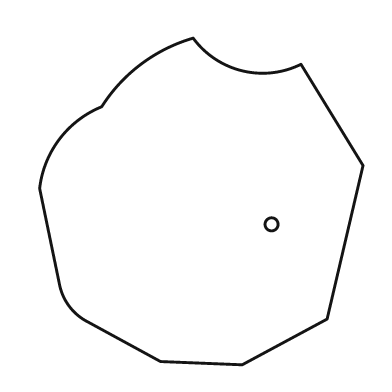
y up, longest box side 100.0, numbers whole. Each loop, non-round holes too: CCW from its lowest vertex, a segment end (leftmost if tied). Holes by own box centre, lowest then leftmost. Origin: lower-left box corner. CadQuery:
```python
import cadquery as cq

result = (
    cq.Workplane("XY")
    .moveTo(62.0, 0.0)
    .lineTo(88.0, 14.0)
    .lineTo(99.0, 61.0)
    .lineTo(80.0, 92.0)
    .threePointArc((62.0, 90.0), (47.0, 100.0))
    .threePointArc((31.0, 92.0), (19.0, 79.0))
    .threePointArc((6.0, 69.0), (0.0, 54.0))
    .lineTo(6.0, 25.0)
    .threePointArc((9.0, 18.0), (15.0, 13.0))
    .lineTo(37.0, 1.0)
    .close()
    .moveTo(71.0, 43.0)
    .circle(2.0)
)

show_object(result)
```